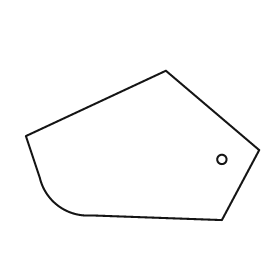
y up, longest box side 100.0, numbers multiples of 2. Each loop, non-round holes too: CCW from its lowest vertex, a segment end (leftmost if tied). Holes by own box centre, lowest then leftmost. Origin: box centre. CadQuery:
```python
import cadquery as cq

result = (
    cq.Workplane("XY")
    .moveTo(34.0, -32.0)
    .lineTo(50.0, -2.0)
    .lineTo(10.0, 32.0)
    .lineTo(-50.0, 4.0)
    .lineTo(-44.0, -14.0)
    .threePointArc((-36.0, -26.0), (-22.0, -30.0))
    .close()
    .moveTo(34.0, -6.0)
    .circle(2.0)
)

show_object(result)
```